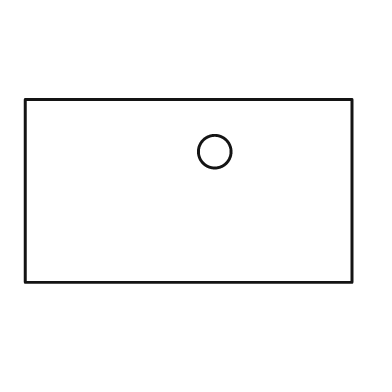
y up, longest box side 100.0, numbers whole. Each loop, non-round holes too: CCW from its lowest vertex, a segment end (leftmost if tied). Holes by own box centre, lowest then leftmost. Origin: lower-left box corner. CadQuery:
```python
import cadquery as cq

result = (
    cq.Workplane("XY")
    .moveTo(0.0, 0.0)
    .lineTo(100.0, 0.0)
    .lineTo(100.0, 56.0)
    .lineTo(0.0, 56.0)
    .close()
    .moveTo(58.0, 40.0)
    .circle(5.0)
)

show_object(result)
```